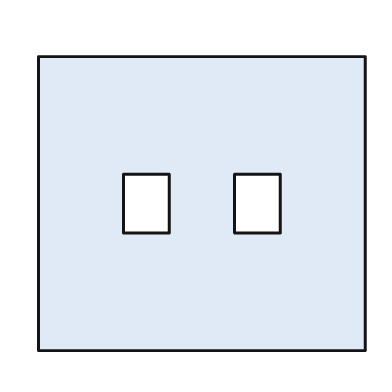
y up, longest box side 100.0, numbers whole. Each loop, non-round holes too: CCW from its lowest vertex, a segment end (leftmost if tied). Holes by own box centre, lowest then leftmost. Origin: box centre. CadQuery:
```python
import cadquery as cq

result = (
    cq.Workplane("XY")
    .moveTo(-50.0, -45.0)
    .lineTo(50.0, -45.0)
    .lineTo(50.0, 45.0)
    .lineTo(-50.0, 45.0)
    .close()
    .moveTo(-24.0, -9.0)
    .lineTo(-10.0, -9.0)
    .lineTo(-10.0, 9.0)
    .lineTo(-24.0, 9.0)
    .close()
    .moveTo(10.0, -9.0)
    .lineTo(24.0, -9.0)
    .lineTo(24.0, 9.0)
    .lineTo(10.0, 9.0)
    .close()
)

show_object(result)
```